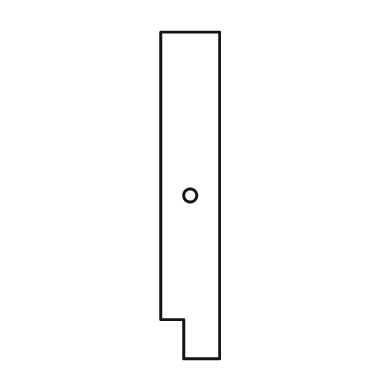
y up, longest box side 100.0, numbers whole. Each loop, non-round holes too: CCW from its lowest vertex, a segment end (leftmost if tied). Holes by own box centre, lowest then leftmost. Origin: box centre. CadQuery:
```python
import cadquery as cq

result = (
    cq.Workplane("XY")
    .moveTo(-2.0, -50.0)
    .lineTo(9.0, -50.0)
    .lineTo(9.0, 50.0)
    .lineTo(-9.0, 50.0)
    .lineTo(-9.0, -38.0)
    .lineTo(-2.0, -38.0)
    .close()
    .moveTo(0.0, 0.0)
    .circle(2.0)
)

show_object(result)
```